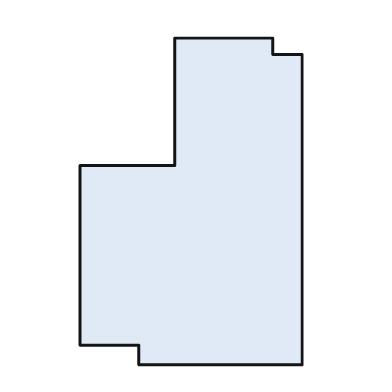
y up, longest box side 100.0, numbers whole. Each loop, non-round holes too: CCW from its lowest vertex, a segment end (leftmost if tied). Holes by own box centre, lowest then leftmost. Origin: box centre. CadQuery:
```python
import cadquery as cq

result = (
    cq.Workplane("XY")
    .moveTo(-16.0, -50.0)
    .lineTo(34.0, -50.0)
    .lineTo(34.0, 45.0)
    .lineTo(25.0, 45.0)
    .lineTo(25.0, 50.0)
    .lineTo(-5.0, 50.0)
    .lineTo(-5.0, 11.0)
    .lineTo(-34.0, 11.0)
    .lineTo(-34.0, -44.0)
    .lineTo(-16.0, -44.0)
    .close()
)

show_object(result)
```